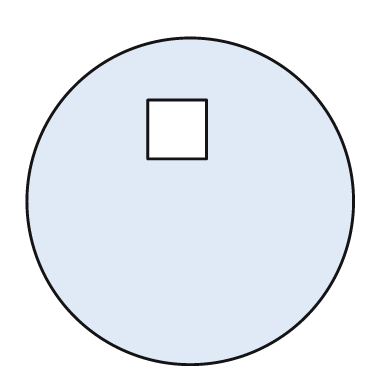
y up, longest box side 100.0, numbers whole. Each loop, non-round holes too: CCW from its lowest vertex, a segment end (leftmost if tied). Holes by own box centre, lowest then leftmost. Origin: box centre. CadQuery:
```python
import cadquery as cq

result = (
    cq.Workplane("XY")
    .moveTo(0.0, 0.0)
    .circle(50.0)
    .moveTo(-13.0, 13.0)
    .lineTo(5.0, 13.0)
    .lineTo(5.0, 31.0)
    .lineTo(-13.0, 31.0)
    .close()
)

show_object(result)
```